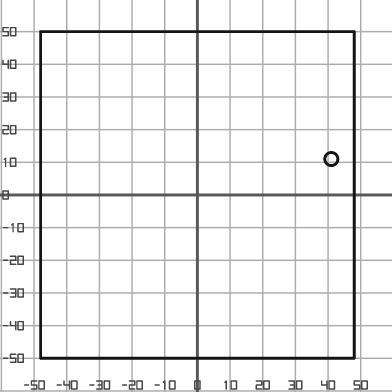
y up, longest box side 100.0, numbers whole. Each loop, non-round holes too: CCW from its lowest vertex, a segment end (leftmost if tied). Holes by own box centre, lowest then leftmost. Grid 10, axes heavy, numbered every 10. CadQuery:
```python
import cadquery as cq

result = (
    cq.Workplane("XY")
    .moveTo(-48.0, -50.0)
    .lineTo(48.0, -50.0)
    .lineTo(48.0, 50.0)
    .lineTo(-48.0, 50.0)
    .close()
    .moveTo(41.0, 11.0)
    .circle(2.0)
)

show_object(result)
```